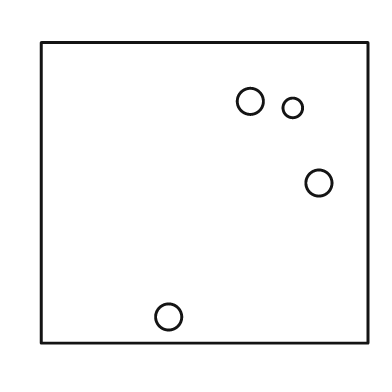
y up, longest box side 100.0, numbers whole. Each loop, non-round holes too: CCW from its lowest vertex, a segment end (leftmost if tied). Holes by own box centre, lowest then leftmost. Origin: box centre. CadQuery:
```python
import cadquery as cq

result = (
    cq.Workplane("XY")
    .moveTo(-50.0, -46.0)
    .lineTo(50.0, -46.0)
    .lineTo(50.0, 46.0)
    .lineTo(-50.0, 46.0)
    .close()
    .moveTo(-11.0, -38.0)
    .circle(4.0)
    .moveTo(35.0, 3.0)
    .circle(4.0)
    .moveTo(27.0, 26.0)
    .circle(3.0)
    .moveTo(14.0, 28.0)
    .circle(4.0)
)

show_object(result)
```